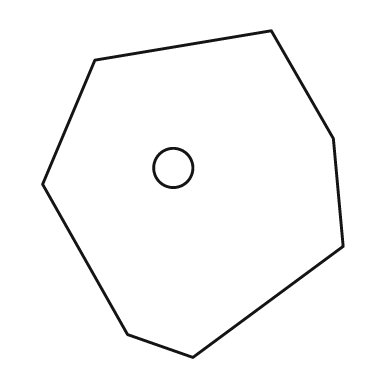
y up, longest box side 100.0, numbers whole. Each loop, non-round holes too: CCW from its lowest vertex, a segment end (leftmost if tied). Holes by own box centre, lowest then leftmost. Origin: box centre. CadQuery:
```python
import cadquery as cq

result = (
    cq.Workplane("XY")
    .moveTo(0.0, -50.0)
    .lineTo(46.0, -16.0)
    .lineTo(43.0, 17.0)
    .lineTo(24.0, 50.0)
    .lineTo(-30.0, 41.0)
    .lineTo(-46.0, 3.0)
    .lineTo(-20.0, -43.0)
    .close()
    .moveTo(-6.0, 8.0)
    .circle(6.0)
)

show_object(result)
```